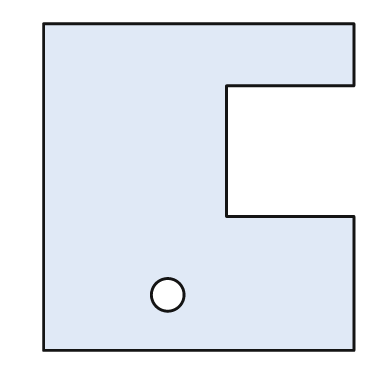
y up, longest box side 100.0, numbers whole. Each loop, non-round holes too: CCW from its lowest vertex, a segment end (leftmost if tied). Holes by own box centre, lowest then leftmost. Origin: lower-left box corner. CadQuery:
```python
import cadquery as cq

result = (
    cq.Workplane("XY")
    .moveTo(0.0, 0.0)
    .lineTo(95.0, 0.0)
    .lineTo(95.0, 41.0)
    .lineTo(56.0, 41.0)
    .lineTo(56.0, 81.0)
    .lineTo(95.0, 81.0)
    .lineTo(95.0, 100.0)
    .lineTo(0.0, 100.0)
    .close()
    .moveTo(38.0, 17.0)
    .circle(5.0)
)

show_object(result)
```